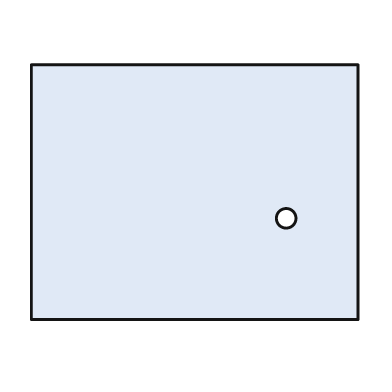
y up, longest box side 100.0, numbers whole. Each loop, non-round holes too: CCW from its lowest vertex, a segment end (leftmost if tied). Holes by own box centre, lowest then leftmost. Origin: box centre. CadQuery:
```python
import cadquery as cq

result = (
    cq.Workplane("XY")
    .moveTo(-50.0, -39.0)
    .lineTo(50.0, -39.0)
    .lineTo(50.0, 39.0)
    .lineTo(-50.0, 39.0)
    .close()
    .moveTo(28.0, -8.0)
    .circle(3.0)
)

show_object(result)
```